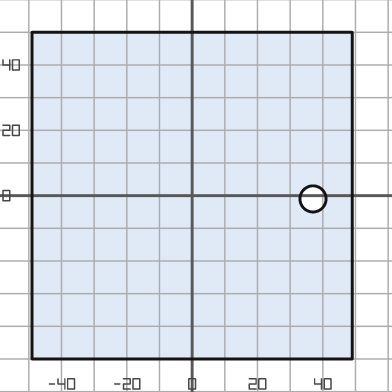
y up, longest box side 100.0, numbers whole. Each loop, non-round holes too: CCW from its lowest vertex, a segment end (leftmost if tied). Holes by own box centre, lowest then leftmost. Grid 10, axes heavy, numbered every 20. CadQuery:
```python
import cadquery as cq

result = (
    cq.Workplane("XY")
    .moveTo(-49.0, -50.0)
    .lineTo(49.0, -50.0)
    .lineTo(49.0, 50.0)
    .lineTo(-49.0, 50.0)
    .close()
    .moveTo(37.0, -1.0)
    .circle(4.0)
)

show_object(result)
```